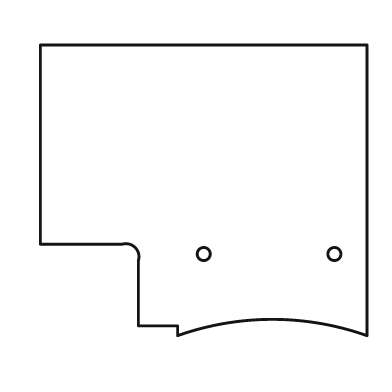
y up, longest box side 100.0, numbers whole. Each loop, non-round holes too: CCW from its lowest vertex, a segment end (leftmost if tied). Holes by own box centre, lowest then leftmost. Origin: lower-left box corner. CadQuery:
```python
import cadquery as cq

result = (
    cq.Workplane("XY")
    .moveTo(42.0, 0.0)
    .threePointArc((71.0, 5.0), (100.0, 0.0))
    .lineTo(100.0, 89.0)
    .lineTo(0.0, 89.0)
    .lineTo(0.0, 28.0)
    .lineTo(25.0, 28.0)
    .threePointArc((29.0, 27.0), (30.0, 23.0))
    .lineTo(30.0, 3.0)
    .lineTo(42.0, 3.0)
    .close()
    .moveTo(50.0, 25.0)
    .circle(2.0)
    .moveTo(90.0, 25.0)
    .circle(2.0)
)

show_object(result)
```